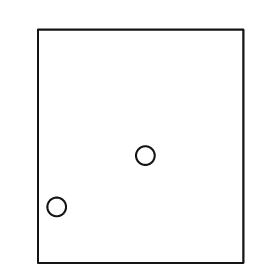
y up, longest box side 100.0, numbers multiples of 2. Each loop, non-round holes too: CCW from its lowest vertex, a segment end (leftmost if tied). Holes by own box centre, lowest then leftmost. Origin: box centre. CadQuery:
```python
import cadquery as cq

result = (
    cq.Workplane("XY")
    .moveTo(-44.0, -50.0)
    .lineTo(44.0, -50.0)
    .lineTo(44.0, 50.0)
    .lineTo(-44.0, 50.0)
    .close()
    .moveTo(-36.0, -26.0)
    .circle(4.0)
    .moveTo(2.0, -4.0)
    .circle(4.0)
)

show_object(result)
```